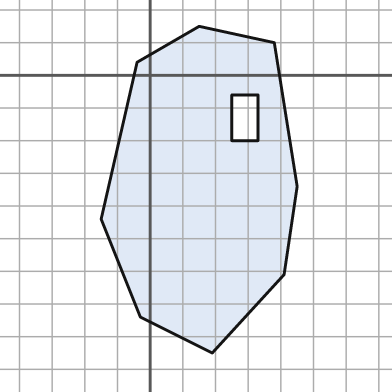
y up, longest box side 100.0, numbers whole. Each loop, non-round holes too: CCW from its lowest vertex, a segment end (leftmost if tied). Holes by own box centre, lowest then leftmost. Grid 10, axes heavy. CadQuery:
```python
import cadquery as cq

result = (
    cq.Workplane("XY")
    .moveTo(19.0, -85.0)
    .lineTo(41.0, -61.0)
    .lineTo(45.0, -34.0)
    .lineTo(38.0, 10.0)
    .lineTo(15.0, 15.0)
    .lineTo(-4.0, 4.0)
    .lineTo(-15.0, -44.0)
    .lineTo(-3.0, -74.0)
    .close()
    .moveTo(25.0, -20.0)
    .lineTo(33.0, -20.0)
    .lineTo(33.0, -6.0)
    .lineTo(25.0, -6.0)
    .close()
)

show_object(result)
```